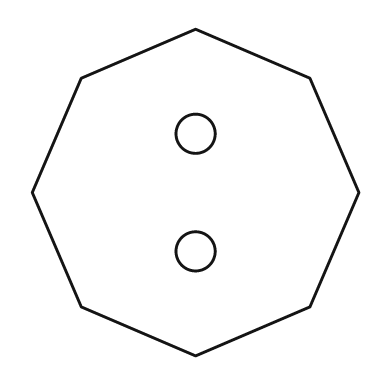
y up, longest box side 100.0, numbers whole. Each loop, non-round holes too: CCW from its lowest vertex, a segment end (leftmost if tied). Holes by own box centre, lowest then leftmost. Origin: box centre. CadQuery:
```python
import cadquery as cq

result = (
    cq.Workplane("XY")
    .moveTo(0.0, -50.0)
    .lineTo(35.0, -35.0)
    .lineTo(50.0, 0.0)
    .lineTo(35.0, 35.0)
    .lineTo(0.0, 50.0)
    .lineTo(-35.0, 35.0)
    .lineTo(-50.0, 0.0)
    .lineTo(-35.0, -35.0)
    .close()
    .moveTo(0.0, -18.0)
    .circle(6.0)
    .moveTo(0.0, 18.0)
    .circle(6.0)
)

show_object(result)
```